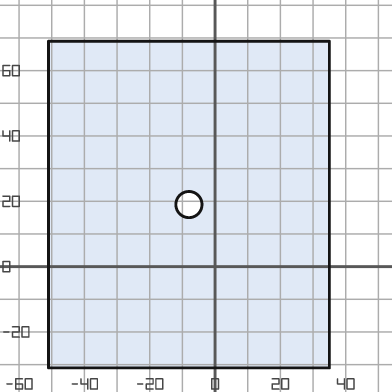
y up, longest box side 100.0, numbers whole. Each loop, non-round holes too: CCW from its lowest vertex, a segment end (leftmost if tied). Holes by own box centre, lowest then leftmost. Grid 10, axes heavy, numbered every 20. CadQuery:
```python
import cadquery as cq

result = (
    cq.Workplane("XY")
    .moveTo(-51.0, -31.0)
    .lineTo(35.0, -31.0)
    .lineTo(35.0, 69.0)
    .lineTo(-51.0, 69.0)
    .close()
    .moveTo(-8.0, 19.0)
    .circle(4.0)
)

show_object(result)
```